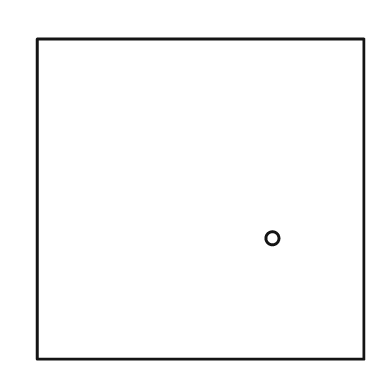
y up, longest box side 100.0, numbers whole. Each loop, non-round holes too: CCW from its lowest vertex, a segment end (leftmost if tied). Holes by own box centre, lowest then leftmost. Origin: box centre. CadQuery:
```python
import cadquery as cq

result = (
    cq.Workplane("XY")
    .moveTo(-50.0, -49.0)
    .lineTo(50.0, -49.0)
    .lineTo(50.0, 49.0)
    .lineTo(-50.0, 49.0)
    .close()
    .moveTo(22.0, -12.0)
    .circle(2.0)
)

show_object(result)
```